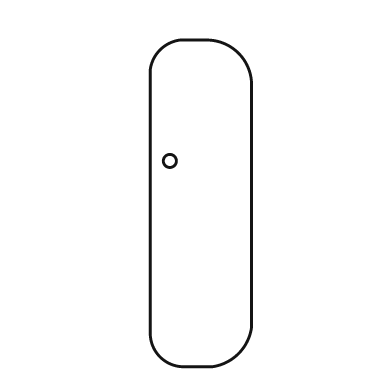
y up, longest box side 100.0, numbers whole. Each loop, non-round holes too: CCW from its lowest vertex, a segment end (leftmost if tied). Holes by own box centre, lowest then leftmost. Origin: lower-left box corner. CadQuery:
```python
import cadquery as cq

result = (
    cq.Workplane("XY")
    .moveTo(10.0, 0.0)
    .lineTo(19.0, 0.0)
    .threePointArc((27.0, 4.0), (31.0, 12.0))
    .lineTo(31.0, 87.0)
    .threePointArc((27.0, 96.0), (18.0, 100.0))
    .lineTo(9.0, 100.0)
    .threePointArc((3.0, 97.0), (0.0, 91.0))
    .lineTo(0.0, 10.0)
    .threePointArc((3.0, 3.0), (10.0, 0.0))
    .close()
    .moveTo(6.0, 63.0)
    .circle(2.0)
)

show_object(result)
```